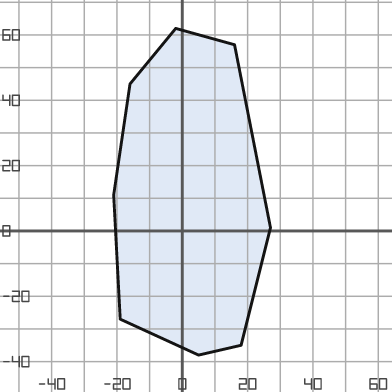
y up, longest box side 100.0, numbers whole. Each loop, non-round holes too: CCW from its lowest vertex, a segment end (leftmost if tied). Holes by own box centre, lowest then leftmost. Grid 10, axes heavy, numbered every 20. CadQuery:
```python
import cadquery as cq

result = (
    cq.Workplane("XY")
    .moveTo(5.0, -38.0)
    .lineTo(18.0, -35.0)
    .lineTo(27.0, 1.0)
    .lineTo(16.0, 57.0)
    .lineTo(-2.0, 62.0)
    .lineTo(-16.0, 45.0)
    .lineTo(-21.0, 11.0)
    .lineTo(-19.0, -27.0)
    .close()
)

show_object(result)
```